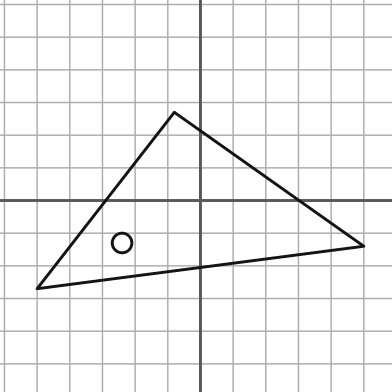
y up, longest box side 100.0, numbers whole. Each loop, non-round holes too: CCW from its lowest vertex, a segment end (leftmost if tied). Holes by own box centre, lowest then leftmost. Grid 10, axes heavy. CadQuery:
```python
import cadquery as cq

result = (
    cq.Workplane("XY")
    .moveTo(-50.0, -27.0)
    .lineTo(50.0, -14.0)
    .lineTo(-8.0, 27.0)
    .close()
    .moveTo(-24.0, -13.0)
    .circle(3.0)
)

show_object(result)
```